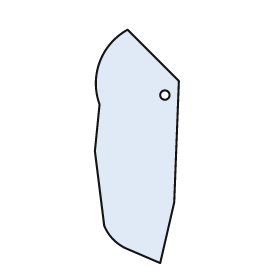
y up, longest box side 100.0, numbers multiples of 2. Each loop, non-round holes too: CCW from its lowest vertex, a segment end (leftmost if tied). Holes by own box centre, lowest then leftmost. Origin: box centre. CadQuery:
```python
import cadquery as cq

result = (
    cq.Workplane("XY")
    .moveTo(10.0, -50.0)
    .lineTo(16.0, -24.0)
    .lineTo(18.0, 28.0)
    .lineTo(-4.0, 50.0)
    .threePointArc((-16.0, 36.0), (-16.0, 18.0))
    .lineTo(-18.0, -2.0)
    .lineTo(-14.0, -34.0)
    .threePointArc((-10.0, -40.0), (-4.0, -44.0))
    .close()
    .moveTo(12.0, 22.0)
    .circle(2.0)
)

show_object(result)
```